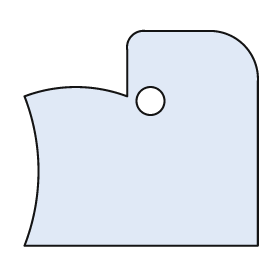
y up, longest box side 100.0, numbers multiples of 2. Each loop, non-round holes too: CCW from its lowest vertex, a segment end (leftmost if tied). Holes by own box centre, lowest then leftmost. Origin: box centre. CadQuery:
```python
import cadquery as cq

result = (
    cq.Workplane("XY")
    .moveTo(-50.0, -46.0)
    .lineTo(50.0, -46.0)
    .lineTo(50.0, 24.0)
    .threePointArc((44.0, 40.0), (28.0, 46.0))
    .lineTo(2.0, 46.0)
    .threePointArc((-4.0, 44.0), (-6.0, 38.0))
    .lineTo(-6.0, 18.0)
    .threePointArc((-28.0, 22.0), (-50.0, 18.0))
    .threePointArc((-44.0, -14.0), (-50.0, -46.0))
    .close()
    .moveTo(4.0, 16.0)
    .circle(6.0)
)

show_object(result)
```